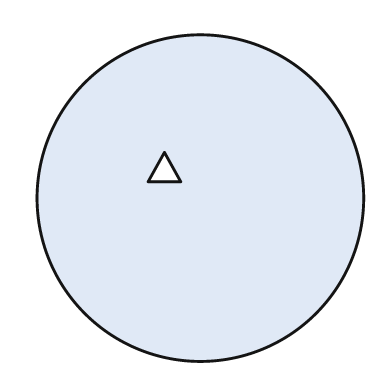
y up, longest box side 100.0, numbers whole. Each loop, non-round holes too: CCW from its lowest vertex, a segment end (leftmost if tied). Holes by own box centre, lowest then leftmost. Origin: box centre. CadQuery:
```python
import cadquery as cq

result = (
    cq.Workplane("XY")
    .moveTo(0.0, 0.0)
    .circle(50.0)
    .moveTo(-16.0, 5.0)
    .lineTo(-6.0, 5.0)
    .lineTo(-11.0, 14.0)
    .close()
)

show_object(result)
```